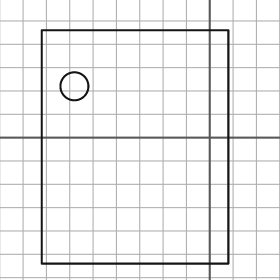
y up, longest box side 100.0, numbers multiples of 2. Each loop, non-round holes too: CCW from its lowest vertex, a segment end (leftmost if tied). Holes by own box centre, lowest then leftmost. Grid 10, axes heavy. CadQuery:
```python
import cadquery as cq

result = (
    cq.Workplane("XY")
    .moveTo(-72.0, -54.0)
    .lineTo(8.0, -54.0)
    .lineTo(8.0, 46.0)
    .lineTo(-72.0, 46.0)
    .close()
    .moveTo(-58.0, 22.0)
    .circle(6.0)
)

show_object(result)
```